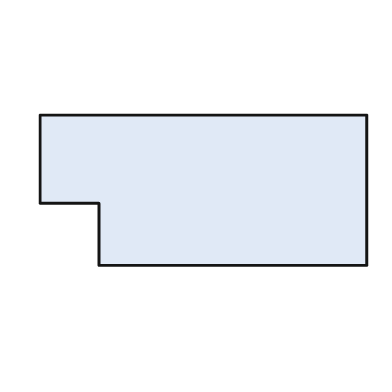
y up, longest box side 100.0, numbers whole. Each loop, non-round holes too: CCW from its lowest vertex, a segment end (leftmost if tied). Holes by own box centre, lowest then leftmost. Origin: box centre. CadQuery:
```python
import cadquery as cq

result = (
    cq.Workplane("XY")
    .moveTo(-32.0, -23.0)
    .lineTo(50.0, -23.0)
    .lineTo(50.0, 23.0)
    .lineTo(-50.0, 23.0)
    .lineTo(-50.0, -4.0)
    .lineTo(-32.0, -4.0)
    .close()
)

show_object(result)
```